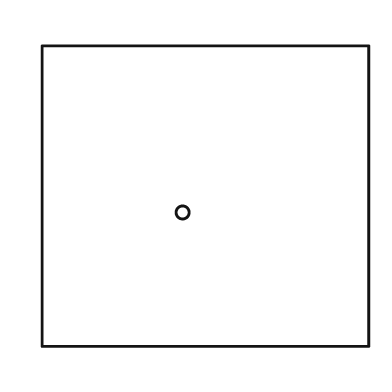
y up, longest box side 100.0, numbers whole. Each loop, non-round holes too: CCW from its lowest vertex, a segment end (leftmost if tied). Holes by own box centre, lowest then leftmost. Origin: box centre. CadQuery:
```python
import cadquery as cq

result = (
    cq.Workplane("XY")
    .moveTo(-50.0, -46.0)
    .lineTo(50.0, -46.0)
    .lineTo(50.0, 46.0)
    .lineTo(-50.0, 46.0)
    .close()
    .moveTo(-7.0, -5.0)
    .circle(2.0)
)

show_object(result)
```